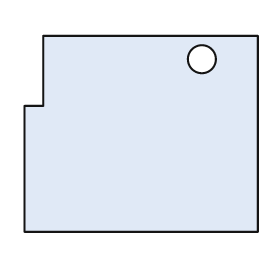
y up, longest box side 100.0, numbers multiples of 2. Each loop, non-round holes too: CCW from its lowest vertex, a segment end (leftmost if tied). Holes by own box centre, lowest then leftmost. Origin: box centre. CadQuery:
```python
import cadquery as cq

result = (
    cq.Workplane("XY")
    .moveTo(-50.0, -42.0)
    .lineTo(50.0, -42.0)
    .lineTo(50.0, 42.0)
    .lineTo(-42.0, 42.0)
    .lineTo(-42.0, 12.0)
    .lineTo(-50.0, 12.0)
    .close()
    .moveTo(26.0, 32.0)
    .circle(6.0)
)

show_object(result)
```